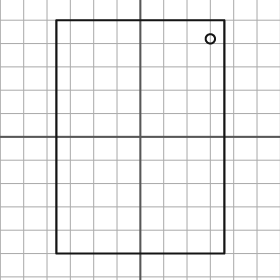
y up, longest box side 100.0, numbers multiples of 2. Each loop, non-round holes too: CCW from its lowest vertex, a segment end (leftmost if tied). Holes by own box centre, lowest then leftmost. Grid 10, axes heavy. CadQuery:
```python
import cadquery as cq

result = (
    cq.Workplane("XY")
    .moveTo(-36.0, -50.0)
    .lineTo(36.0, -50.0)
    .lineTo(36.0, 50.0)
    .lineTo(-36.0, 50.0)
    .close()
    .moveTo(30.0, 42.0)
    .circle(2.0)
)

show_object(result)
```